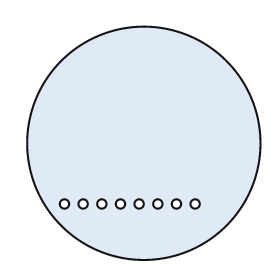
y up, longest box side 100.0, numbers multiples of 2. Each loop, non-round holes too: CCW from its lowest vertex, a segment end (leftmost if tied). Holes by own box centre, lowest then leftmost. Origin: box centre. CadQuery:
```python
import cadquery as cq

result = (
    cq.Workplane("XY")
    .moveTo(0.0, 0.0)
    .circle(50.0)
    .moveTo(-34.0, -26.0)
    .circle(2.0)
    .moveTo(-26.0, -26.0)
    .circle(2.0)
    .moveTo(-18.0, -26.0)
    .circle(2.0)
    .moveTo(-10.0, -26.0)
    .circle(2.0)
    .moveTo(-2.0, -26.0)
    .circle(2.0)
    .moveTo(6.0, -26.0)
    .circle(2.0)
    .moveTo(14.0, -26.0)
    .circle(2.0)
    .moveTo(22.0, -26.0)
    .circle(2.0)
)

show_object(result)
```